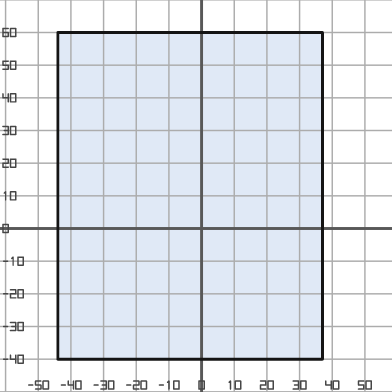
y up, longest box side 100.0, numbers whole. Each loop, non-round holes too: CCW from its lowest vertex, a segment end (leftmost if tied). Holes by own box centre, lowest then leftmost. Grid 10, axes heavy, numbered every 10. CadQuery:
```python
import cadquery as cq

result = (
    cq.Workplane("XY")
    .moveTo(-44.0, -40.0)
    .lineTo(37.0, -40.0)
    .lineTo(37.0, 60.0)
    .lineTo(-44.0, 60.0)
    .close()
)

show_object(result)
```